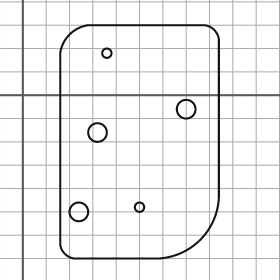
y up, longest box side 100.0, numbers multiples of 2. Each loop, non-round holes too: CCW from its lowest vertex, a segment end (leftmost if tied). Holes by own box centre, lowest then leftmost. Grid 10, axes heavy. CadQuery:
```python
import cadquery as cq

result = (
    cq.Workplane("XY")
    .moveTo(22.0, -70.0)
    .lineTo(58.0, -70.0)
    .threePointArc((76.0, -62.0), (84.0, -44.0))
    .lineTo(84.0, 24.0)
    .threePointArc((82.0, 28.0), (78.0, 30.0))
    .lineTo(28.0, 30.0)
    .threePointArc((20.0, 26.0), (16.0, 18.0))
    .lineTo(16.0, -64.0)
    .threePointArc((18.0, -68.0), (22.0, -70.0))
    .close()
    .moveTo(24.0, -50.0)
    .circle(4.0)
    .moveTo(50.0, -48.0)
    .circle(2.0)
    .moveTo(32.0, -16.0)
    .circle(4.0)
    .moveTo(70.0, -6.0)
    .circle(4.0)
    .moveTo(36.0, 18.0)
    .circle(2.0)
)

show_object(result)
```